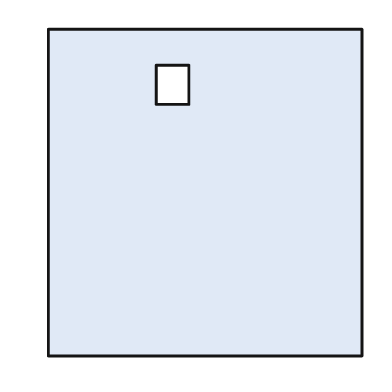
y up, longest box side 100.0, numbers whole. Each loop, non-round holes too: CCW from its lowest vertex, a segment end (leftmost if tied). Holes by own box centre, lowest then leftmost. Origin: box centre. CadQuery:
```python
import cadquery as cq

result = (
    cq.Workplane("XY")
    .moveTo(-48.0, -50.0)
    .lineTo(48.0, -50.0)
    .lineTo(48.0, 50.0)
    .lineTo(-48.0, 50.0)
    .close()
    .moveTo(-15.0, 27.0)
    .lineTo(-5.0, 27.0)
    .lineTo(-5.0, 39.0)
    .lineTo(-15.0, 39.0)
    .close()
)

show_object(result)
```